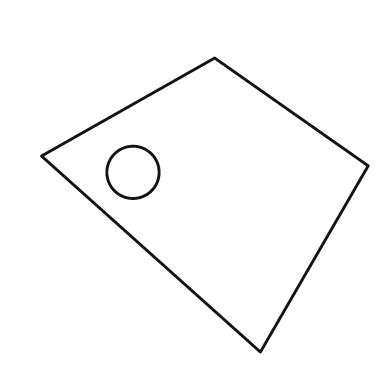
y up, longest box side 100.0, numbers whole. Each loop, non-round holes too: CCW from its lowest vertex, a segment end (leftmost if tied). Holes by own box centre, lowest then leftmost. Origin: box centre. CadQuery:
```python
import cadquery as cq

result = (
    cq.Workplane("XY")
    .moveTo(17.0, -45.0)
    .lineTo(50.0, 12.0)
    .lineTo(3.0, 45.0)
    .lineTo(-50.0, 15.0)
    .close()
    .moveTo(-22.0, 10.0)
    .circle(8.0)
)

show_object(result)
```